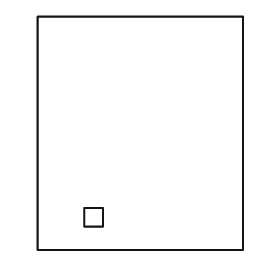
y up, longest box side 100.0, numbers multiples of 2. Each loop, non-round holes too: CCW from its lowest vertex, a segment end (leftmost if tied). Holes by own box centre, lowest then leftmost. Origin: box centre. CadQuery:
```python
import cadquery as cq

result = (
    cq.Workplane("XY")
    .moveTo(-44.0, -50.0)
    .lineTo(44.0, -50.0)
    .lineTo(44.0, 50.0)
    .lineTo(-44.0, 50.0)
    .close()
    .moveTo(-24.0, -40.0)
    .lineTo(-16.0, -40.0)
    .lineTo(-16.0, -32.0)
    .lineTo(-24.0, -32.0)
    .close()
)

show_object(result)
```